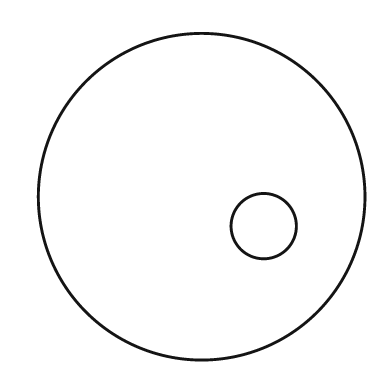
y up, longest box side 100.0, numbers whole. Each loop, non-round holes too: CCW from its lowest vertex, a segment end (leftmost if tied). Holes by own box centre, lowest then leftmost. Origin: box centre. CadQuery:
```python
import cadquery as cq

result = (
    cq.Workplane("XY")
    .moveTo(0.0, 0.0)
    .circle(50.0)
    .moveTo(19.0, -9.0)
    .circle(10.0)
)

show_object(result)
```